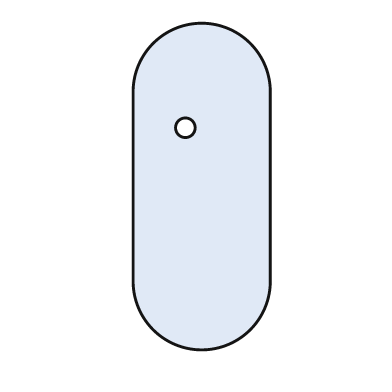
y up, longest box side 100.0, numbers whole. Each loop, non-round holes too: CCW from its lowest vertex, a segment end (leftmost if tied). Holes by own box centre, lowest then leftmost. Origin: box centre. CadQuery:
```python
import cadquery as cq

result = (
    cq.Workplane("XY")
    .moveTo(-21.0, -29.0)
    .threePointArc((0.0, -50.0), (21.0, -29.0))
    .lineTo(21.0, 29.0)
    .threePointArc((0.0, 50.0), (-21.0, 29.0))
    .close()
    .moveTo(-5.0, 18.0)
    .circle(3.0)
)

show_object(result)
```